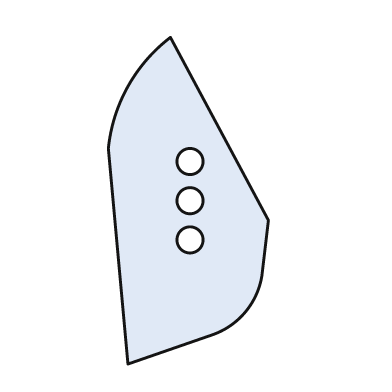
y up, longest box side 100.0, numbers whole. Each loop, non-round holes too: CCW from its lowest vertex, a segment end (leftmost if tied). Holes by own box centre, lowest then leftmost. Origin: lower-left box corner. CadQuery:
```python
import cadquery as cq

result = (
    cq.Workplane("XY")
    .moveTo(6.0, 0.0)
    .lineTo(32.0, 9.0)
    .threePointArc((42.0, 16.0), (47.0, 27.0))
    .lineTo(49.0, 44.0)
    .lineTo(19.0, 100.0)
    .threePointArc((6.0, 85.0), (0.0, 66.0))
    .close()
    .moveTo(25.0, 38.0)
    .circle(4.0)
    .moveTo(25.0, 50.0)
    .circle(4.0)
    .moveTo(25.0, 62.0)
    .circle(4.0)
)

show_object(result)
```